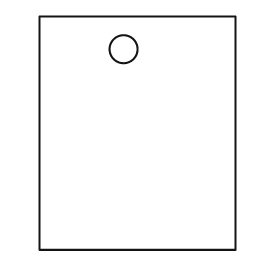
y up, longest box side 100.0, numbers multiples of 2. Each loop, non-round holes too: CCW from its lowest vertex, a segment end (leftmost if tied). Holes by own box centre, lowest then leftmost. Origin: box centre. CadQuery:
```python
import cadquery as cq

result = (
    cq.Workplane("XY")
    .moveTo(-42.0, -50.0)
    .lineTo(42.0, -50.0)
    .lineTo(42.0, 50.0)
    .lineTo(-42.0, 50.0)
    .close()
    .moveTo(-6.0, 36.0)
    .circle(6.0)
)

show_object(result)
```